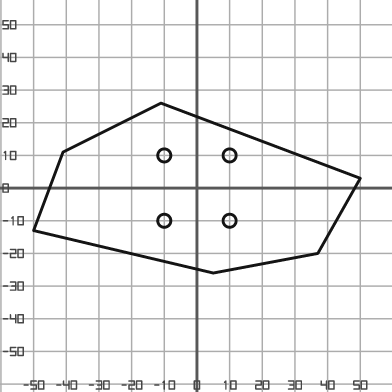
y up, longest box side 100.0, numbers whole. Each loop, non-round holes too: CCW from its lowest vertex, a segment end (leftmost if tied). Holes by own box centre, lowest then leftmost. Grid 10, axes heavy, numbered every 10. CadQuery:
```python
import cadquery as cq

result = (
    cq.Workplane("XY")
    .moveTo(5.0, -26.0)
    .lineTo(37.0, -20.0)
    .lineTo(50.0, 3.0)
    .lineTo(-11.0, 26.0)
    .lineTo(-41.0, 11.0)
    .lineTo(-50.0, -13.0)
    .close()
    .moveTo(-10.0, -10.0)
    .circle(2.0)
    .moveTo(10.0, -10.0)
    .circle(2.0)
    .moveTo(-10.0, 10.0)
    .circle(2.0)
    .moveTo(10.0, 10.0)
    .circle(2.0)
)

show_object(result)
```